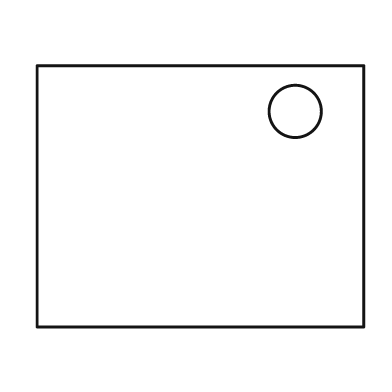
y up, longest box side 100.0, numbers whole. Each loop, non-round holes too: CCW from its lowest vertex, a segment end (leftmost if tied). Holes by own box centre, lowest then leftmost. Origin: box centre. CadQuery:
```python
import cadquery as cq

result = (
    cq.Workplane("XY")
    .moveTo(-50.0, -40.0)
    .lineTo(50.0, -40.0)
    .lineTo(50.0, 40.0)
    .lineTo(-50.0, 40.0)
    .close()
    .moveTo(29.0, 26.0)
    .circle(8.0)
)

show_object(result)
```